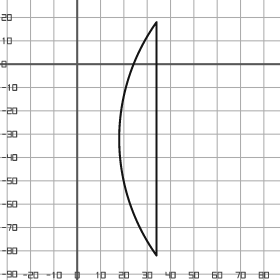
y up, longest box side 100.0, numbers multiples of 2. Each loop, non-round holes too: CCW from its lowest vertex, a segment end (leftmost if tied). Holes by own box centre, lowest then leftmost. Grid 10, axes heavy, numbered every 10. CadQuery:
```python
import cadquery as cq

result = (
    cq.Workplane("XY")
    .moveTo(34.0, -82.0)
    .lineTo(34.0, 18.0)
    .threePointArc((18.0, -32.0), (34.0, -82.0))
    .close()
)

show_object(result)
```